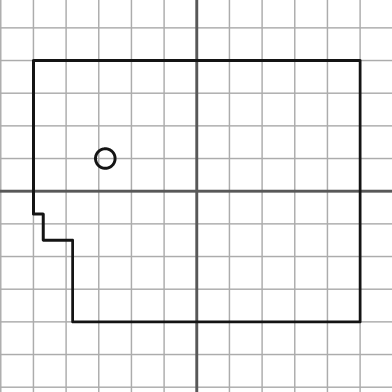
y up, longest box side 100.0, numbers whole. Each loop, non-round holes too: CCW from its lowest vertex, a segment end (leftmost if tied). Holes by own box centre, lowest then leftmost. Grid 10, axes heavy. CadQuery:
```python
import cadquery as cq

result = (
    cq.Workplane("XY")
    .moveTo(-38.0, -40.0)
    .lineTo(50.0, -40.0)
    .lineTo(50.0, 40.0)
    .lineTo(-50.0, 40.0)
    .lineTo(-50.0, -7.0)
    .lineTo(-47.0, -7.0)
    .lineTo(-47.0, -15.0)
    .lineTo(-38.0, -15.0)
    .close()
    .moveTo(-28.0, 10.0)
    .circle(3.0)
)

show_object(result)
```